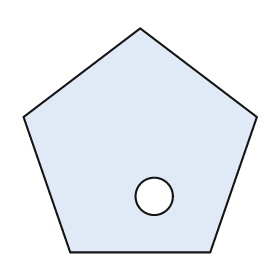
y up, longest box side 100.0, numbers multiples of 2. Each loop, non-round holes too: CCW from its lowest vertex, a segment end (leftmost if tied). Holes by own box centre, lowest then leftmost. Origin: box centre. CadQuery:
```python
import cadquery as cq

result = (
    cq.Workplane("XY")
    .moveTo(-30.0, -48.0)
    .lineTo(30.0, -48.0)
    .lineTo(50.0, 10.0)
    .lineTo(0.0, 48.0)
    .lineTo(-50.0, 10.0)
    .close()
    .moveTo(6.0, -24.0)
    .circle(8.0)
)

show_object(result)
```